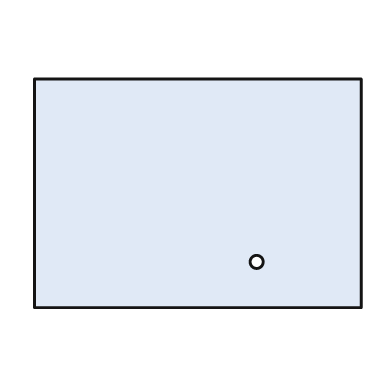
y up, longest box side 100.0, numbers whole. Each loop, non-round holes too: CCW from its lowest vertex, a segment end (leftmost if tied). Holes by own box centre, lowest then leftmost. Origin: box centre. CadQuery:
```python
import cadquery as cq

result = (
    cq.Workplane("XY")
    .moveTo(-50.0, -35.0)
    .lineTo(50.0, -35.0)
    .lineTo(50.0, 35.0)
    .lineTo(-50.0, 35.0)
    .close()
    .moveTo(18.0, -21.0)
    .circle(2.0)
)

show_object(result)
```